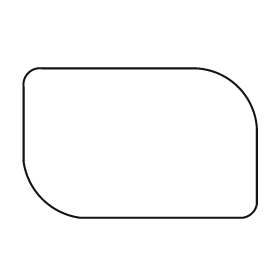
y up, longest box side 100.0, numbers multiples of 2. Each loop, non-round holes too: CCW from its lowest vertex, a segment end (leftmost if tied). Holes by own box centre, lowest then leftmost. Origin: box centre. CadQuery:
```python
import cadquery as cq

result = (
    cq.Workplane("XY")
    .moveTo(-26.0, -32.0)
    .lineTo(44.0, -32.0)
    .threePointArc((48.0, -30.0), (50.0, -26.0))
    .lineTo(50.0, 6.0)
    .threePointArc((42.0, 24.0), (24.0, 32.0))
    .lineTo(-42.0, 32.0)
    .threePointArc((-48.0, 30.0), (-50.0, 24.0))
    .lineTo(-50.0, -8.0)
    .threePointArc((-42.0, -24.0), (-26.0, -32.0))
    .close()
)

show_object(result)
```